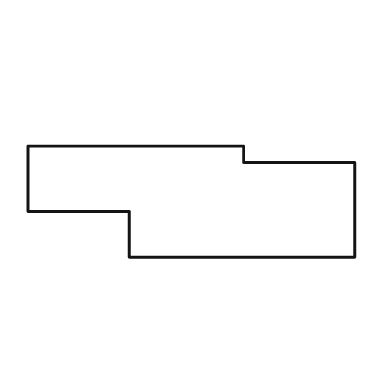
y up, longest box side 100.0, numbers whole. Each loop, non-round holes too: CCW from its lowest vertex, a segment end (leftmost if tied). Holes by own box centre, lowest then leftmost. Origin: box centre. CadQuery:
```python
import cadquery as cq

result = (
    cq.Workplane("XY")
    .moveTo(-19.0, -17.0)
    .lineTo(50.0, -17.0)
    .lineTo(50.0, 12.0)
    .lineTo(16.0, 12.0)
    .lineTo(16.0, 17.0)
    .lineTo(-50.0, 17.0)
    .lineTo(-50.0, -3.0)
    .lineTo(-19.0, -3.0)
    .close()
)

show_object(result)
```